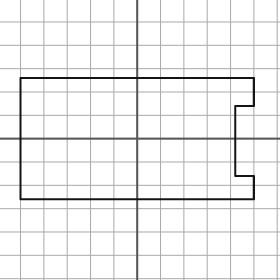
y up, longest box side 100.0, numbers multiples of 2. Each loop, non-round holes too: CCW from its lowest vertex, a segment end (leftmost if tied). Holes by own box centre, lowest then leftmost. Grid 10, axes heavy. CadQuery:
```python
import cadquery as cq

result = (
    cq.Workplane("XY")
    .moveTo(-50.0, -26.0)
    .lineTo(50.0, -26.0)
    .lineTo(50.0, -16.0)
    .lineTo(42.0, -16.0)
    .lineTo(42.0, 14.0)
    .lineTo(50.0, 14.0)
    .lineTo(50.0, 26.0)
    .lineTo(-50.0, 26.0)
    .close()
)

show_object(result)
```